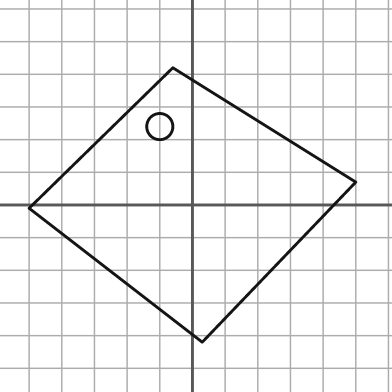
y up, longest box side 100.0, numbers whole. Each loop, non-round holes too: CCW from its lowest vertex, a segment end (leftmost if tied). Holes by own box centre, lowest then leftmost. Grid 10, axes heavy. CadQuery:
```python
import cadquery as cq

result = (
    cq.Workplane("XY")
    .moveTo(3.0, -42.0)
    .lineTo(50.0, 7.0)
    .lineTo(-6.0, 42.0)
    .lineTo(-50.0, -1.0)
    .close()
    .moveTo(-10.0, 24.0)
    .circle(4.0)
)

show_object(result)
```